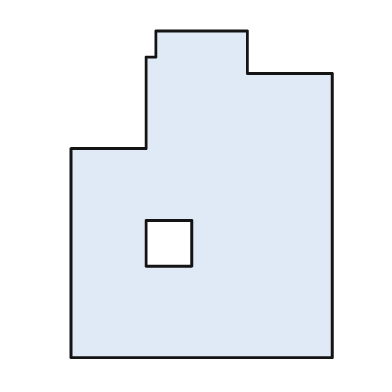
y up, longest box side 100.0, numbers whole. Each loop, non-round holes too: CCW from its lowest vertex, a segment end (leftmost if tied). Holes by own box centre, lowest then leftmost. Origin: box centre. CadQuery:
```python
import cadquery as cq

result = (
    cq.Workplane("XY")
    .moveTo(-40.0, -50.0)
    .lineTo(40.0, -50.0)
    .lineTo(40.0, 37.0)
    .lineTo(14.0, 37.0)
    .lineTo(14.0, 50.0)
    .lineTo(-14.0, 50.0)
    .lineTo(-14.0, 42.0)
    .lineTo(-17.0, 42.0)
    .lineTo(-17.0, 14.0)
    .lineTo(-40.0, 14.0)
    .close()
    .moveTo(-17.0, -22.0)
    .lineTo(-3.0, -22.0)
    .lineTo(-3.0, -8.0)
    .lineTo(-17.0, -8.0)
    .close()
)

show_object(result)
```